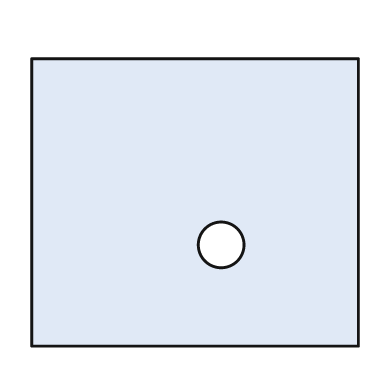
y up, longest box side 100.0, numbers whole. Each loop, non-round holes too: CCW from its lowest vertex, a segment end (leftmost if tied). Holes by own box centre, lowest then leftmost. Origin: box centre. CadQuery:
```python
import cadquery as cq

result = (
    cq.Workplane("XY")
    .moveTo(-50.0, -44.0)
    .lineTo(50.0, -44.0)
    .lineTo(50.0, 44.0)
    .lineTo(-50.0, 44.0)
    .close()
    .moveTo(8.0, -13.0)
    .circle(7.0)
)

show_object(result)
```